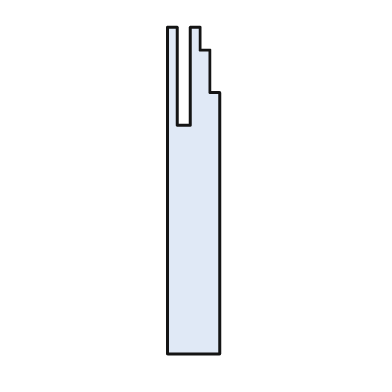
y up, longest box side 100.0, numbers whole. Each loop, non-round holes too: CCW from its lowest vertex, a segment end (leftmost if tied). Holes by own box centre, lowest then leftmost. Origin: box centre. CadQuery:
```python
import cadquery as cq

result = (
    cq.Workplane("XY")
    .moveTo(-8.0, -50.0)
    .lineTo(8.0, -50.0)
    .lineTo(8.0, 30.0)
    .lineTo(5.0, 30.0)
    .lineTo(5.0, 43.0)
    .lineTo(2.0, 43.0)
    .lineTo(2.0, 50.0)
    .lineTo(-1.0, 50.0)
    .lineTo(-1.0, 20.0)
    .lineTo(-5.0, 20.0)
    .lineTo(-5.0, 50.0)
    .lineTo(-8.0, 50.0)
    .close()
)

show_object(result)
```